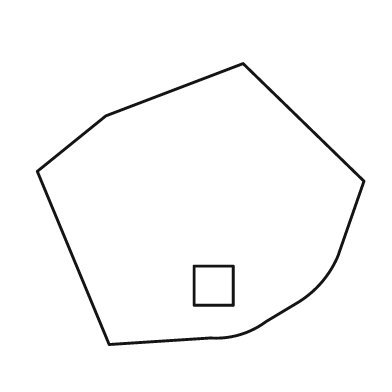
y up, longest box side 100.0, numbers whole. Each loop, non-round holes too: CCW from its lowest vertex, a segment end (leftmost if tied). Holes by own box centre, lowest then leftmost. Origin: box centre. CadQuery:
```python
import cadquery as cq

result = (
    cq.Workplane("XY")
    .moveTo(-28.0, -43.0)
    .lineTo(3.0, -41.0)
    .threePointArc((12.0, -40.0), (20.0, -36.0))
    .lineTo(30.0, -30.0)
    .threePointArc((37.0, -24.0), (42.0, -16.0))
    .lineTo(50.0, 7.0)
    .lineTo(13.0, 43.0)
    .lineTo(-29.0, 27.0)
    .lineTo(-50.0, 10.0)
    .close()
    .moveTo(-2.0, -31.0)
    .lineTo(10.0, -31.0)
    .lineTo(10.0, -19.0)
    .lineTo(-2.0, -19.0)
    .close()
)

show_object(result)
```